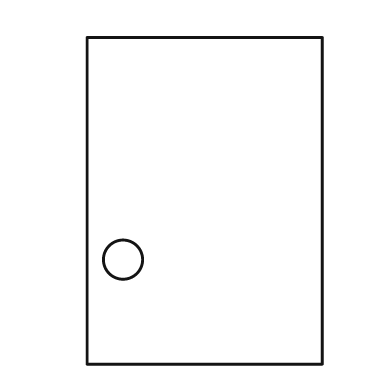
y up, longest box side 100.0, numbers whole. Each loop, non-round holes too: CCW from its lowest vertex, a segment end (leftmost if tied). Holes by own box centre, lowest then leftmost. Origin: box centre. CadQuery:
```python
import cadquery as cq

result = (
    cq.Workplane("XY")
    .moveTo(-36.0, -50.0)
    .lineTo(36.0, -50.0)
    .lineTo(36.0, 50.0)
    .lineTo(-36.0, 50.0)
    .close()
    .moveTo(-25.0, -18.0)
    .circle(6.0)
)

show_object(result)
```